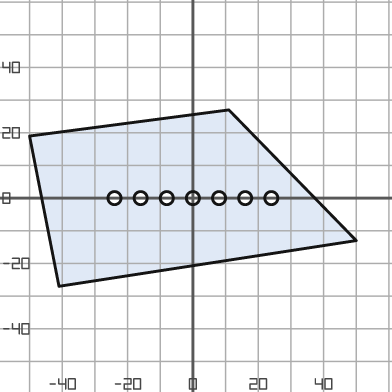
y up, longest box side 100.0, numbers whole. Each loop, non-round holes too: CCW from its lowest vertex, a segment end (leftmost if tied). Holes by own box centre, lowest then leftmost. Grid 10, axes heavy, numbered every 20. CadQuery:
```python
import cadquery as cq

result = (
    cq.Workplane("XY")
    .moveTo(-41.0, -27.0)
    .lineTo(50.0, -13.0)
    .lineTo(11.0, 27.0)
    .lineTo(-50.0, 19.0)
    .close()
    .moveTo(-24.0, 0.0)
    .circle(2.0)
    .moveTo(-16.0, 0.0)
    .circle(2.0)
    .moveTo(-8.0, 0.0)
    .circle(2.0)
    .moveTo(0.0, 0.0)
    .circle(2.0)
    .moveTo(8.0, 0.0)
    .circle(2.0)
    .moveTo(16.0, 0.0)
    .circle(2.0)
    .moveTo(24.0, 0.0)
    .circle(2.0)
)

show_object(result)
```